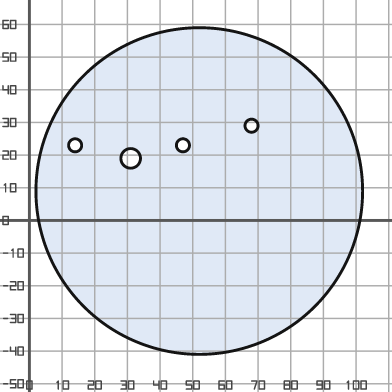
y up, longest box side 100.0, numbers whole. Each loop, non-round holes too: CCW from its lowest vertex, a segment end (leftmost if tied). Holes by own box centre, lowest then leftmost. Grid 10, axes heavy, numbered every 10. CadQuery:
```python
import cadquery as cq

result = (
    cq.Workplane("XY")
    .moveTo(52.0, 9.0)
    .circle(50.0)
    .moveTo(31.0, 19.0)
    .circle(3.0)
    .moveTo(14.0, 23.0)
    .circle(2.0)
    .moveTo(47.0, 23.0)
    .circle(2.0)
    .moveTo(68.0, 29.0)
    .circle(2.0)
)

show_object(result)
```